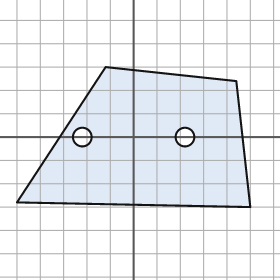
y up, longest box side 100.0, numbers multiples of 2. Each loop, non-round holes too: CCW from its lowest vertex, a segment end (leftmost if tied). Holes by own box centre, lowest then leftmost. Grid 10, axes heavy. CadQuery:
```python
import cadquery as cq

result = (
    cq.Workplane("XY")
    .moveTo(50.0, -30.0)
    .lineTo(44.0, 24.0)
    .lineTo(-12.0, 30.0)
    .lineTo(-50.0, -28.0)
    .close()
    .moveTo(-22.0, 0.0)
    .circle(4.0)
    .moveTo(22.0, 0.0)
    .circle(4.0)
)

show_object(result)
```